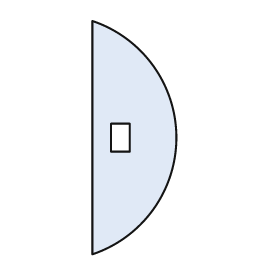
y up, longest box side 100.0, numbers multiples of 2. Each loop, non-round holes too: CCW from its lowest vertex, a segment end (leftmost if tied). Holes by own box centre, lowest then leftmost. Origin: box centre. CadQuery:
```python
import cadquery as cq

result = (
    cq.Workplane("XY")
    .moveTo(-18.0, -50.0)
    .threePointArc((18.0, 0.0), (-18.0, 50.0))
    .close()
    .moveTo(-10.0, -6.0)
    .lineTo(-2.0, -6.0)
    .lineTo(-2.0, 6.0)
    .lineTo(-10.0, 6.0)
    .close()
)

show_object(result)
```